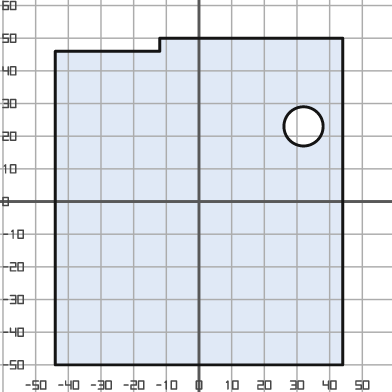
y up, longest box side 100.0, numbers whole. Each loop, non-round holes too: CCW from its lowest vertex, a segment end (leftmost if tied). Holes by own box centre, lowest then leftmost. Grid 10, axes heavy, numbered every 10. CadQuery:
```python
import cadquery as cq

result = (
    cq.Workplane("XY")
    .moveTo(-44.0, -50.0)
    .lineTo(44.0, -50.0)
    .lineTo(44.0, 50.0)
    .lineTo(-12.0, 50.0)
    .lineTo(-12.0, 46.0)
    .lineTo(-44.0, 46.0)
    .close()
    .moveTo(32.0, 23.0)
    .circle(6.0)
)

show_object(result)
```